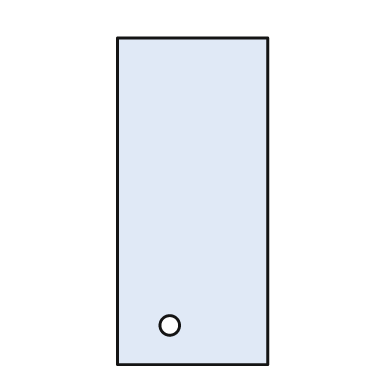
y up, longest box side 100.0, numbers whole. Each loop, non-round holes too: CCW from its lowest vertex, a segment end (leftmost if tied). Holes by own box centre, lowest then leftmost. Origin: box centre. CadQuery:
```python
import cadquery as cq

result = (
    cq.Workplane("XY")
    .moveTo(-23.0, -50.0)
    .lineTo(23.0, -50.0)
    .lineTo(23.0, 50.0)
    .lineTo(-23.0, 50.0)
    .close()
    .moveTo(-7.0, -38.0)
    .circle(3.0)
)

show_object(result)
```